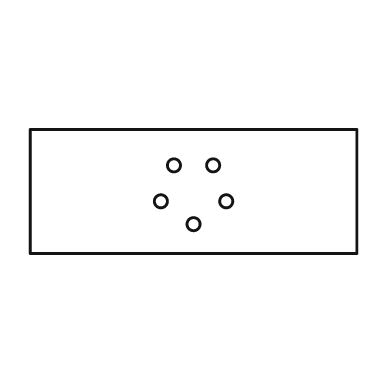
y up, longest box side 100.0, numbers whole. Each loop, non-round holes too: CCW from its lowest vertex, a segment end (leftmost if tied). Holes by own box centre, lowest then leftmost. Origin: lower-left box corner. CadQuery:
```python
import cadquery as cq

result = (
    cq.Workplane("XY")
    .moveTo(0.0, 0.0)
    .lineTo(100.0, 0.0)
    .lineTo(100.0, 38.0)
    .lineTo(0.0, 38.0)
    .close()
    .moveTo(50.0, 9.0)
    .circle(2.0)
    .moveTo(40.0, 16.0)
    .circle(2.0)
    .moveTo(60.0, 16.0)
    .circle(2.0)
    .moveTo(44.0, 27.0)
    .circle(2.0)
    .moveTo(56.0, 27.0)
    .circle(2.0)
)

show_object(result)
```